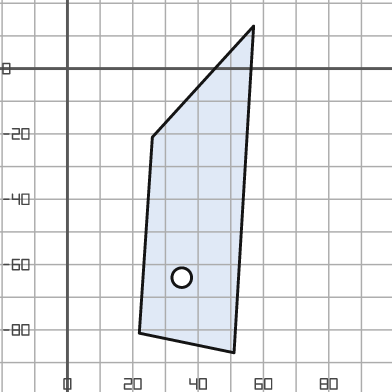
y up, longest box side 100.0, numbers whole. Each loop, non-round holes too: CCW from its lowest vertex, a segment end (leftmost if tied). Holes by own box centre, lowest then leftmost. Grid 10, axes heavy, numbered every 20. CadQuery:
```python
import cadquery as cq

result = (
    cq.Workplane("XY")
    .moveTo(51.0, -87.0)
    .lineTo(57.0, 13.0)
    .lineTo(26.0, -21.0)
    .lineTo(22.0, -81.0)
    .close()
    .moveTo(35.0, -64.0)
    .circle(3.0)
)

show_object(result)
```